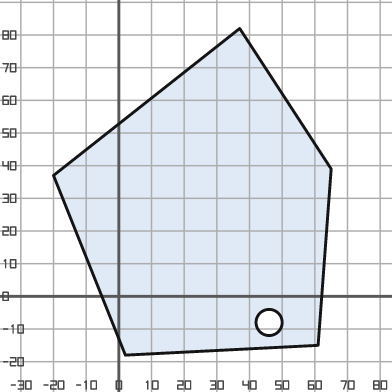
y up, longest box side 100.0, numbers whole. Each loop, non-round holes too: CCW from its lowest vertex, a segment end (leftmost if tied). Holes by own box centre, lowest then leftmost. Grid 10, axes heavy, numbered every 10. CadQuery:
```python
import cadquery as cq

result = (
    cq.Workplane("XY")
    .moveTo(2.0, -18.0)
    .lineTo(61.0, -15.0)
    .lineTo(65.0, 39.0)
    .lineTo(37.0, 82.0)
    .lineTo(-20.0, 37.0)
    .close()
    .moveTo(46.0, -8.0)
    .circle(4.0)
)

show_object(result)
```